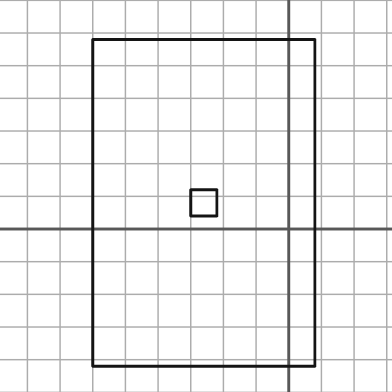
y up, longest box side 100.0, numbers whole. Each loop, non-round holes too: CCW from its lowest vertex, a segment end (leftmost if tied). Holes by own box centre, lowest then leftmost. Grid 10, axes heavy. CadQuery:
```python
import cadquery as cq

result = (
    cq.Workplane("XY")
    .moveTo(-60.0, -42.0)
    .lineTo(8.0, -42.0)
    .lineTo(8.0, 58.0)
    .lineTo(-60.0, 58.0)
    .close()
    .moveTo(-30.0, 4.0)
    .lineTo(-22.0, 4.0)
    .lineTo(-22.0, 12.0)
    .lineTo(-30.0, 12.0)
    .close()
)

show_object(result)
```